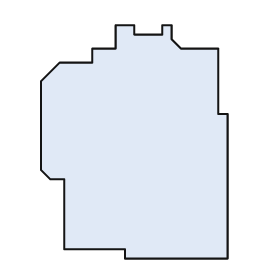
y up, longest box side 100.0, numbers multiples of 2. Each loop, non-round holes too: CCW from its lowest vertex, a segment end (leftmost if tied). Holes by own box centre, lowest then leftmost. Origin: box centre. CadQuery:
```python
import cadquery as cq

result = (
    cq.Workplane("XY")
    .moveTo(-4.0, -50.0)
    .lineTo(40.0, -50.0)
    .lineTo(40.0, 12.0)
    .lineTo(36.0, 12.0)
    .lineTo(36.0, 40.0)
    .lineTo(20.0, 40.0)
    .lineTo(16.0, 44.0)
    .lineTo(16.0, 50.0)
    .lineTo(12.0, 50.0)
    .lineTo(12.0, 46.0)
    .lineTo(0.0, 46.0)
    .lineTo(0.0, 50.0)
    .lineTo(-8.0, 50.0)
    .lineTo(-8.0, 40.0)
    .lineTo(-18.0, 40.0)
    .lineTo(-18.0, 34.0)
    .lineTo(-32.0, 34.0)
    .lineTo(-40.0, 26.0)
    .lineTo(-40.0, -12.0)
    .lineTo(-36.0, -16.0)
    .lineTo(-30.0, -16.0)
    .lineTo(-30.0, -46.0)
    .lineTo(-4.0, -46.0)
    .close()
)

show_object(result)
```